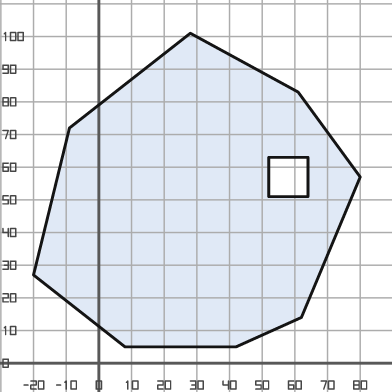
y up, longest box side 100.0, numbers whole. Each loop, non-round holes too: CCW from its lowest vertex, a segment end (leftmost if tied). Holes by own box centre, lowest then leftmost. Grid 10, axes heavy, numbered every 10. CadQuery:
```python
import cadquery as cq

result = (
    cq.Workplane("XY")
    .moveTo(8.0, 5.0)
    .lineTo(42.0, 5.0)
    .lineTo(62.0, 14.0)
    .lineTo(80.0, 57.0)
    .lineTo(61.0, 83.0)
    .lineTo(28.0, 101.0)
    .lineTo(-9.0, 72.0)
    .lineTo(-20.0, 27.0)
    .close()
    .moveTo(52.0, 51.0)
    .lineTo(64.0, 51.0)
    .lineTo(64.0, 63.0)
    .lineTo(52.0, 63.0)
    .close()
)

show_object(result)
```